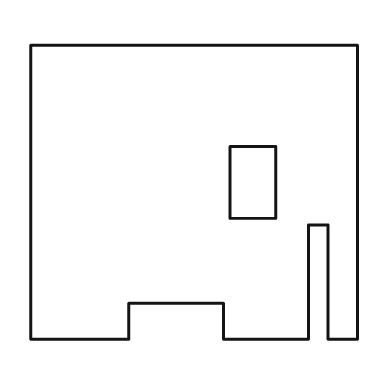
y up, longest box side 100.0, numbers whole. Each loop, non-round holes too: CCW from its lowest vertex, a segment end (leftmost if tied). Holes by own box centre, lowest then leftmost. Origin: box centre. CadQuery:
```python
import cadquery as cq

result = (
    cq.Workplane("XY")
    .moveTo(-50.0, -45.0)
    .lineTo(-20.0, -45.0)
    .lineTo(-20.0, -34.0)
    .lineTo(9.0, -34.0)
    .lineTo(9.0, -45.0)
    .lineTo(35.0, -45.0)
    .lineTo(35.0, -10.0)
    .lineTo(41.0, -10.0)
    .lineTo(41.0, -45.0)
    .lineTo(50.0, -45.0)
    .lineTo(50.0, 45.0)
    .lineTo(-50.0, 45.0)
    .close()
    .moveTo(11.0, -8.0)
    .lineTo(25.0, -8.0)
    .lineTo(25.0, 14.0)
    .lineTo(11.0, 14.0)
    .close()
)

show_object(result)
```